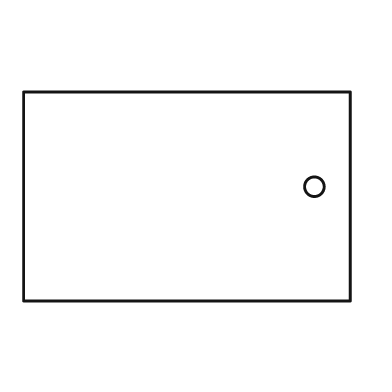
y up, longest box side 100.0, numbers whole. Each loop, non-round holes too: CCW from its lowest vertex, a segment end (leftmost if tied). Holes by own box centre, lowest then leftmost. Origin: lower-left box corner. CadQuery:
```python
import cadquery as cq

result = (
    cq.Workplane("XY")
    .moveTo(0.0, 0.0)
    .lineTo(100.0, 0.0)
    .lineTo(100.0, 64.0)
    .lineTo(0.0, 64.0)
    .close()
    .moveTo(89.0, 35.0)
    .circle(3.0)
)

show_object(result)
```